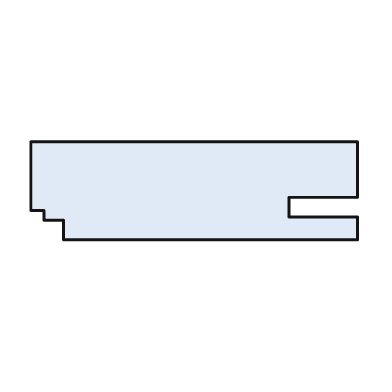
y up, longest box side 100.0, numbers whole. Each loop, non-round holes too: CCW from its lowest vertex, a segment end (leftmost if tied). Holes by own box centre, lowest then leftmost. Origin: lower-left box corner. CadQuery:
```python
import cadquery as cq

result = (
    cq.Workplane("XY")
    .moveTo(10.0, 0.0)
    .lineTo(100.0, 0.0)
    .lineTo(100.0, 7.0)
    .lineTo(79.0, 7.0)
    .lineTo(79.0, 13.0)
    .lineTo(100.0, 13.0)
    .lineTo(100.0, 30.0)
    .lineTo(0.0, 30.0)
    .lineTo(0.0, 9.0)
    .lineTo(4.0, 9.0)
    .lineTo(4.0, 6.0)
    .lineTo(10.0, 6.0)
    .close()
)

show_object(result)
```